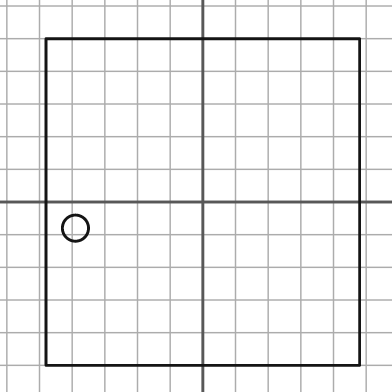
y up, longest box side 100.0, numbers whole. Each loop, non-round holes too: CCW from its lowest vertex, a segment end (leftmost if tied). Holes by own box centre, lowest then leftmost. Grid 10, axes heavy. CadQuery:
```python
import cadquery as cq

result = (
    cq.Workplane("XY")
    .moveTo(-48.0, -50.0)
    .lineTo(48.0, -50.0)
    .lineTo(48.0, 50.0)
    .lineTo(-48.0, 50.0)
    .close()
    .moveTo(-39.0, -8.0)
    .circle(4.0)
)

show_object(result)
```